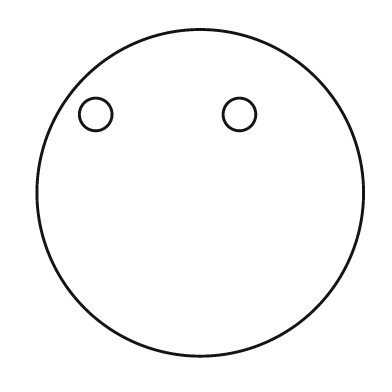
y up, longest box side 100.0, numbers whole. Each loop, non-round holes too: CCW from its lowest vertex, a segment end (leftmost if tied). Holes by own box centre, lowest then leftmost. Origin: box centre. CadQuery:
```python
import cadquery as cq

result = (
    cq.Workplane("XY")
    .moveTo(0.0, 0.0)
    .circle(50.0)
    .moveTo(-32.0, 24.0)
    .circle(5.0)
    .moveTo(12.0, 24.0)
    .circle(5.0)
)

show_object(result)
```